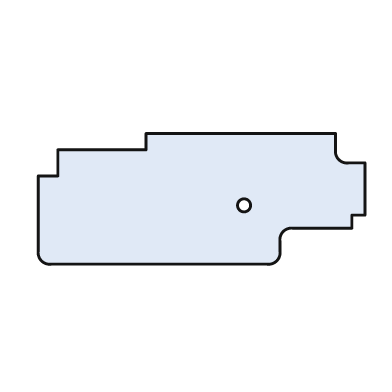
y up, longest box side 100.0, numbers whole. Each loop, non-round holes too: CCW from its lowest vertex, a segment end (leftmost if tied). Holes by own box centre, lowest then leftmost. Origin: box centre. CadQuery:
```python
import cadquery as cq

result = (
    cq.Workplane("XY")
    .moveTo(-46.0, -20.0)
    .lineTo(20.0, -20.0)
    .threePointArc((23.0, -19.0), (24.0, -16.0))
    .lineTo(24.0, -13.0)
    .threePointArc((25.0, -10.0), (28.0, -9.0))
    .lineTo(46.0, -9.0)
    .lineTo(46.0, -5.0)
    .lineTo(50.0, -5.0)
    .lineTo(50.0, 11.0)
    .lineTo(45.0, 11.0)
    .threePointArc((42.0, 12.0), (41.0, 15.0))
    .lineTo(41.0, 20.0)
    .lineTo(-17.0, 20.0)
    .lineTo(-17.0, 15.0)
    .lineTo(-44.0, 15.0)
    .lineTo(-44.0, 7.0)
    .lineTo(-50.0, 7.0)
    .lineTo(-50.0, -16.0)
    .threePointArc((-49.0, -19.0), (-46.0, -20.0))
    .close()
    .moveTo(13.0, -2.0)
    .circle(2.0)
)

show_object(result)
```